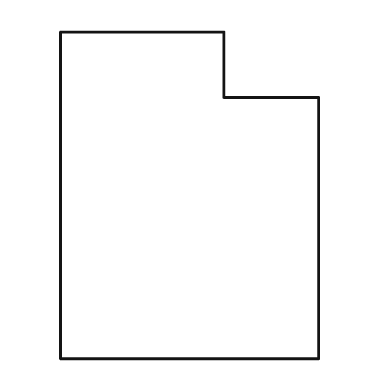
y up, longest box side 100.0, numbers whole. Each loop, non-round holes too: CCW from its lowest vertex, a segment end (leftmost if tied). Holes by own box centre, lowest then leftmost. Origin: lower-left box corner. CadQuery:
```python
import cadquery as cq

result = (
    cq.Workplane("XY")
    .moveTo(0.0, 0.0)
    .lineTo(79.0, 0.0)
    .lineTo(79.0, 80.0)
    .lineTo(50.0, 80.0)
    .lineTo(50.0, 100.0)
    .lineTo(0.0, 100.0)
    .close()
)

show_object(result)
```